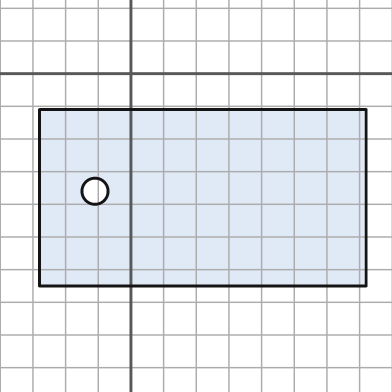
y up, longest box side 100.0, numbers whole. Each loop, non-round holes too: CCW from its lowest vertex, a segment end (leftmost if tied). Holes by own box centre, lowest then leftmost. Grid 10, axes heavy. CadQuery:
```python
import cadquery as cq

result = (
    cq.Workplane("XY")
    .moveTo(-28.0, -65.0)
    .lineTo(72.0, -65.0)
    .lineTo(72.0, -11.0)
    .lineTo(-28.0, -11.0)
    .close()
    .moveTo(-11.0, -36.0)
    .circle(4.0)
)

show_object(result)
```